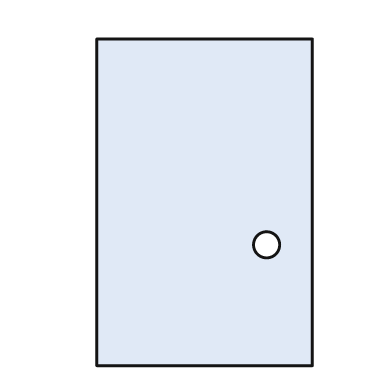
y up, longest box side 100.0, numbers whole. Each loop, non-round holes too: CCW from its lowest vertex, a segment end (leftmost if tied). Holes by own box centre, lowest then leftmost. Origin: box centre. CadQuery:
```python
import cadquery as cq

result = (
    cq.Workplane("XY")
    .moveTo(-33.0, -50.0)
    .lineTo(33.0, -50.0)
    .lineTo(33.0, 50.0)
    .lineTo(-33.0, 50.0)
    .close()
    .moveTo(19.0, -13.0)
    .circle(4.0)
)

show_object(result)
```